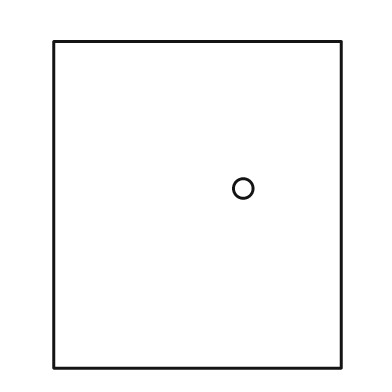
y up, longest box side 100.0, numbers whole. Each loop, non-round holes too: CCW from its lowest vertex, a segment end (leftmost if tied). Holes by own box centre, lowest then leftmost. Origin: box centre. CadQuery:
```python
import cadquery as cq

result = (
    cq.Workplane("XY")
    .moveTo(-44.0, -50.0)
    .lineTo(44.0, -50.0)
    .lineTo(44.0, 50.0)
    .lineTo(-44.0, 50.0)
    .close()
    .moveTo(14.0, 5.0)
    .circle(3.0)
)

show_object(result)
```